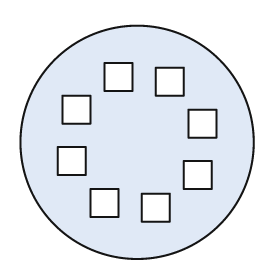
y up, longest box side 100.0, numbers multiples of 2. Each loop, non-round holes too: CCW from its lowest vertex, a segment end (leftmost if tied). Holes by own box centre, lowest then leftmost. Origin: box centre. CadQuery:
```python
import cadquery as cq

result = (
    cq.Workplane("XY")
    .moveTo(0.0, 0.0)
    .circle(50.0)
    .moveTo(2.0, -34.0)
    .lineTo(14.0, -34.0)
    .lineTo(14.0, -22.0)
    .lineTo(2.0, -22.0)
    .close()
    .moveTo(-20.0, -32.0)
    .lineTo(-8.0, -32.0)
    .lineTo(-8.0, -20.0)
    .lineTo(-20.0, -20.0)
    .close()
    .moveTo(20.0, -20.0)
    .lineTo(32.0, -20.0)
    .lineTo(32.0, -8.0)
    .lineTo(20.0, -8.0)
    .close()
    .moveTo(-34.0, -14.0)
    .lineTo(-22.0, -14.0)
    .lineTo(-22.0, -2.0)
    .lineTo(-34.0, -2.0)
    .close()
    .moveTo(22.0, 2.0)
    .lineTo(34.0, 2.0)
    .lineTo(34.0, 14.0)
    .lineTo(22.0, 14.0)
    .close()
    .moveTo(-32.0, 8.0)
    .lineTo(-20.0, 8.0)
    .lineTo(-20.0, 20.0)
    .lineTo(-32.0, 20.0)
    .close()
    .moveTo(8.0, 20.0)
    .lineTo(20.0, 20.0)
    .lineTo(20.0, 32.0)
    .lineTo(8.0, 32.0)
    .close()
    .moveTo(-14.0, 22.0)
    .lineTo(-2.0, 22.0)
    .lineTo(-2.0, 34.0)
    .lineTo(-14.0, 34.0)
    .close()
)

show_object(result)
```